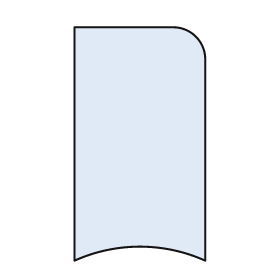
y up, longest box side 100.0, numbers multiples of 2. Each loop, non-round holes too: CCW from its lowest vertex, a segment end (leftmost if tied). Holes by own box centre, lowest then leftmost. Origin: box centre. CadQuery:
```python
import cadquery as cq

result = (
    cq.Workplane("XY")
    .moveTo(-28.0, -50.0)
    .threePointArc((0.0, -44.0), (28.0, -50.0))
    .lineTo(28.0, 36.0)
    .threePointArc((24.0, 46.0), (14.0, 50.0))
    .lineTo(-28.0, 50.0)
    .close()
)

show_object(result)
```